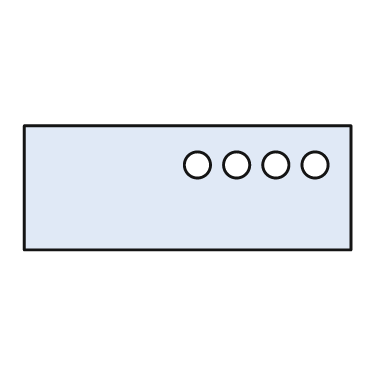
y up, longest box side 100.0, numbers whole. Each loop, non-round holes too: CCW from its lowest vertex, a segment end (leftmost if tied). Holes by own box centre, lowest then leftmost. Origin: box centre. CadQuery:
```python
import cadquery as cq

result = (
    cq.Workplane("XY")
    .moveTo(-50.0, -19.0)
    .lineTo(50.0, -19.0)
    .lineTo(50.0, 19.0)
    .lineTo(-50.0, 19.0)
    .close()
    .moveTo(3.0, 7.0)
    .circle(4.0)
    .moveTo(15.0, 7.0)
    .circle(4.0)
    .moveTo(27.0, 7.0)
    .circle(4.0)
    .moveTo(39.0, 7.0)
    .circle(4.0)
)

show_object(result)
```